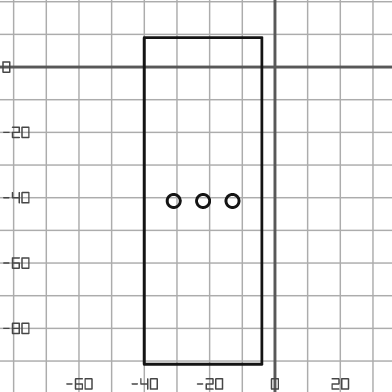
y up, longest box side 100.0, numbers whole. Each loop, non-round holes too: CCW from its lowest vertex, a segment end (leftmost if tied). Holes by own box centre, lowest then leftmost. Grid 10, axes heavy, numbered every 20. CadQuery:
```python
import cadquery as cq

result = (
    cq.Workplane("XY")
    .moveTo(-40.0, -91.0)
    .lineTo(-4.0, -91.0)
    .lineTo(-4.0, 9.0)
    .lineTo(-40.0, 9.0)
    .close()
    .moveTo(-31.0, -41.0)
    .circle(2.0)
    .moveTo(-22.0, -41.0)
    .circle(2.0)
    .moveTo(-13.0, -41.0)
    .circle(2.0)
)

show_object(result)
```